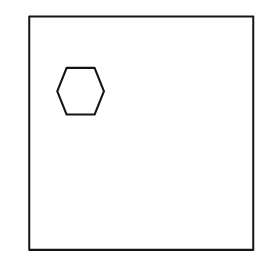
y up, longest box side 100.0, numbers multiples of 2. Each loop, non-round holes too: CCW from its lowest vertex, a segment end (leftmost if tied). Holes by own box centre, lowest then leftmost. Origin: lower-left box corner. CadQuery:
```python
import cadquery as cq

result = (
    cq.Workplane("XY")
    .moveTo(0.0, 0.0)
    .lineTo(96.0, 0.0)
    .lineTo(96.0, 100.0)
    .lineTo(0.0, 100.0)
    .close()
    .moveTo(16.0, 58.0)
    .lineTo(28.0, 58.0)
    .lineTo(32.0, 68.0)
    .lineTo(28.0, 78.0)
    .lineTo(16.0, 78.0)
    .lineTo(12.0, 68.0)
    .close()
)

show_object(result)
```